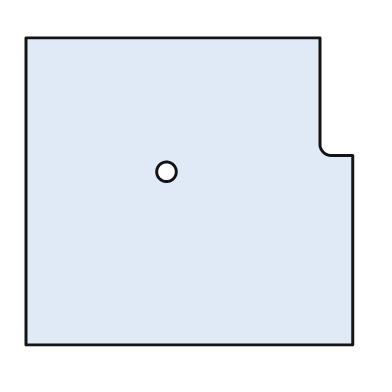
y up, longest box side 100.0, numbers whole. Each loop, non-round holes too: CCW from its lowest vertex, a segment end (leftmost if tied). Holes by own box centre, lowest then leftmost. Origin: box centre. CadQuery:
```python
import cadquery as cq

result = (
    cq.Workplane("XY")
    .moveTo(-50.0, -47.0)
    .lineTo(50.0, -47.0)
    .lineTo(50.0, 11.0)
    .lineTo(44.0, 11.0)
    .threePointArc((41.0, 12.0), (40.0, 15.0))
    .lineTo(40.0, 47.0)
    .lineTo(-50.0, 47.0)
    .close()
    .moveTo(-7.0, 6.0)
    .circle(3.0)
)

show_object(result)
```